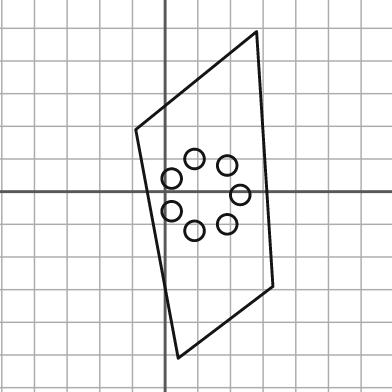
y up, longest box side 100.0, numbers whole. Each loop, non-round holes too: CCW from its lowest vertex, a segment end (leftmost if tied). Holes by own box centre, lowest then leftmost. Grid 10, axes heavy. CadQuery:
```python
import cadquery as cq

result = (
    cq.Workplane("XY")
    .moveTo(4.0, -51.0)
    .lineTo(33.0, -29.0)
    .lineTo(28.0, 49.0)
    .lineTo(-9.0, 19.0)
    .close()
    .moveTo(9.0, -12.0)
    .circle(3.0)
    .moveTo(19.0, -10.0)
    .circle(3.0)
    .moveTo(2.0, -6.0)
    .circle(3.0)
    .moveTo(23.0, -1.0)
    .circle(3.0)
    .moveTo(2.0, 4.0)
    .circle(3.0)
    .moveTo(19.0, 8.0)
    .circle(3.0)
    .moveTo(9.0, 10.0)
    .circle(3.0)
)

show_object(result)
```